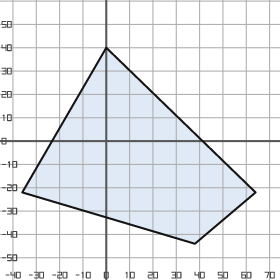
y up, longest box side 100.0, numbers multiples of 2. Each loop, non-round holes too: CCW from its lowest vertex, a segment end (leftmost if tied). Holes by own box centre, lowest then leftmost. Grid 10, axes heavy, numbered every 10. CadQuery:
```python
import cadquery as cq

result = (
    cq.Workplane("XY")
    .moveTo(38.0, -44.0)
    .lineTo(64.0, -22.0)
    .lineTo(0.0, 40.0)
    .lineTo(-36.0, -22.0)
    .close()
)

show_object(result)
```